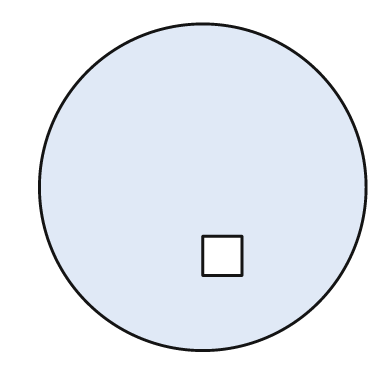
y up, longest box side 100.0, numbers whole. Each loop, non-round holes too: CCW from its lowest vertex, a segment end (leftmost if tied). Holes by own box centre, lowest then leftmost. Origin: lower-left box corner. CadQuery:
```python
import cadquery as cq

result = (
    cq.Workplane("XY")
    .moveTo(50.0, 50.0)
    .circle(50.0)
    .moveTo(50.0, 23.0)
    .lineTo(62.0, 23.0)
    .lineTo(62.0, 35.0)
    .lineTo(50.0, 35.0)
    .close()
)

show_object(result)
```